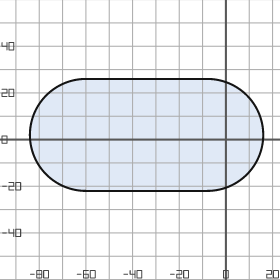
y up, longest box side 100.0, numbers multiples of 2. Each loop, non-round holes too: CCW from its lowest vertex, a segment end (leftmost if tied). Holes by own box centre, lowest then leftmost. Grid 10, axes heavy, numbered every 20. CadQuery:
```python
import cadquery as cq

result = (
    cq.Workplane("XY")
    .moveTo(-60.0, -22.0)
    .lineTo(-8.0, -22.0)
    .threePointArc((16.0, 2.0), (-8.0, 26.0))
    .lineTo(-60.0, 26.0)
    .threePointArc((-84.0, 2.0), (-60.0, -22.0))
    .close()
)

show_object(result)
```